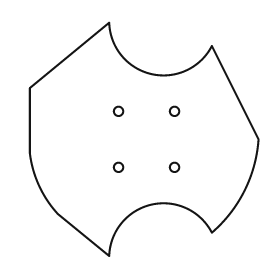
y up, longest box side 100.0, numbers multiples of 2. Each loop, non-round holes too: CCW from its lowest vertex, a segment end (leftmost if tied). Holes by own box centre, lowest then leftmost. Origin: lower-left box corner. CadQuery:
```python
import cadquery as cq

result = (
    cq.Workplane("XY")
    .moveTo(34.0, 0.0)
    .threePointArc((52.0, 22.0), (78.0, 10.0))
    .threePointArc((92.0, 28.0), (98.0, 50.0))
    .lineTo(78.0, 90.0)
    .threePointArc((52.0, 78.0), (34.0, 100.0))
    .lineTo(0.0, 72.0)
    .lineTo(0.0, 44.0)
    .threePointArc((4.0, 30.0), (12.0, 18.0))
    .close()
    .moveTo(38.0, 38.0)
    .circle(2.0)
    .moveTo(62.0, 38.0)
    .circle(2.0)
    .moveTo(38.0, 62.0)
    .circle(2.0)
    .moveTo(62.0, 62.0)
    .circle(2.0)
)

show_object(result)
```